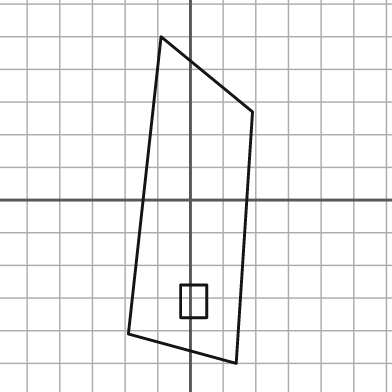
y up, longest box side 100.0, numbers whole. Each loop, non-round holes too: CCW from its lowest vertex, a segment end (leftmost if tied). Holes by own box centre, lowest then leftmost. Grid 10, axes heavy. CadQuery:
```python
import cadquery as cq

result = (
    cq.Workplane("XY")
    .moveTo(14.0, -50.0)
    .lineTo(19.0, 27.0)
    .lineTo(-9.0, 50.0)
    .lineTo(-19.0, -41.0)
    .close()
    .moveTo(-3.0, -36.0)
    .lineTo(5.0, -36.0)
    .lineTo(5.0, -26.0)
    .lineTo(-3.0, -26.0)
    .close()
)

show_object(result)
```